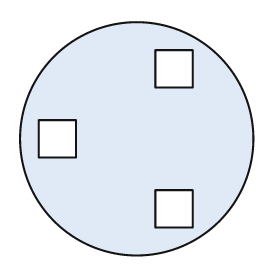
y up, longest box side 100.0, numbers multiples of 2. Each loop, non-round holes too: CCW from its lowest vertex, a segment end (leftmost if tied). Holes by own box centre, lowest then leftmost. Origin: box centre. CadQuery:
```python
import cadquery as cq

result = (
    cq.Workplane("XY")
    .moveTo(0.0, 0.0)
    .circle(50.0)
    .moveTo(8.0, -38.0)
    .lineTo(24.0, -38.0)
    .lineTo(24.0, -22.0)
    .lineTo(8.0, -22.0)
    .close()
    .moveTo(-42.0, -8.0)
    .lineTo(-26.0, -8.0)
    .lineTo(-26.0, 8.0)
    .lineTo(-42.0, 8.0)
    .close()
    .moveTo(8.0, 22.0)
    .lineTo(24.0, 22.0)
    .lineTo(24.0, 38.0)
    .lineTo(8.0, 38.0)
    .close()
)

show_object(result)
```